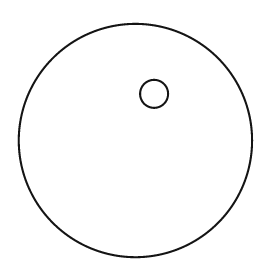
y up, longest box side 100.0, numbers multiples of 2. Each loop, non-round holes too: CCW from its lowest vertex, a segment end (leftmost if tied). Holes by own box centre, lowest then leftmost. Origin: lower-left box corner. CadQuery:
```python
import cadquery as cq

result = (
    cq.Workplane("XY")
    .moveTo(50.0, 50.0)
    .circle(50.0)
    .moveTo(58.0, 70.0)
    .circle(6.0)
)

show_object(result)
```